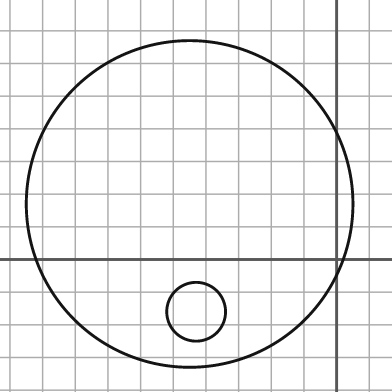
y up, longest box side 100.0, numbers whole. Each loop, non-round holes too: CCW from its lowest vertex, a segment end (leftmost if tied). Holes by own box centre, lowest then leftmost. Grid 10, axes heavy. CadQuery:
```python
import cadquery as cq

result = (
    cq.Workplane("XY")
    .moveTo(-45.0, 17.0)
    .circle(50.0)
    .moveTo(-43.0, -16.0)
    .circle(9.0)
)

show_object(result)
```